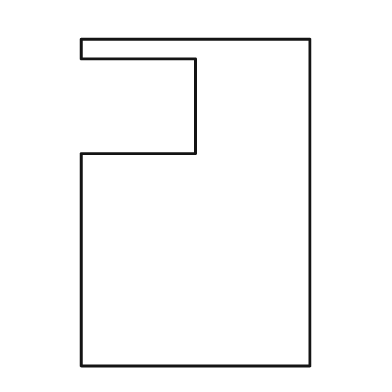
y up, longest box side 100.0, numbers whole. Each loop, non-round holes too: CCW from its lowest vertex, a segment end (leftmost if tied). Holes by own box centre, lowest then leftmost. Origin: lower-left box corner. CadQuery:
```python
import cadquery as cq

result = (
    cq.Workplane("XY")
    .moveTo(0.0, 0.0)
    .lineTo(70.0, 0.0)
    .lineTo(70.0, 100.0)
    .lineTo(0.0, 100.0)
    .lineTo(0.0, 94.0)
    .lineTo(35.0, 94.0)
    .lineTo(35.0, 65.0)
    .lineTo(0.0, 65.0)
    .close()
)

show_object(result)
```